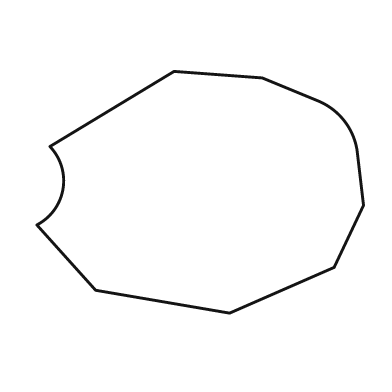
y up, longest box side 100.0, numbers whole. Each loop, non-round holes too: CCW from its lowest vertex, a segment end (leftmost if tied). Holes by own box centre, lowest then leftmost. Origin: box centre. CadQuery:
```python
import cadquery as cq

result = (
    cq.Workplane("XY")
    .moveTo(9.0, -37.0)
    .lineTo(41.0, -23.0)
    .lineTo(50.0, -4.0)
    .lineTo(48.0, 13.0)
    .threePointArc((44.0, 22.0), (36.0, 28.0))
    .lineTo(19.0, 35.0)
    .lineTo(-8.0, 37.0)
    .lineTo(-46.0, 14.0)
    .threePointArc((-42.0, 1.0), (-50.0, -10.0))
    .lineTo(-32.0, -30.0)
    .close()
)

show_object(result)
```